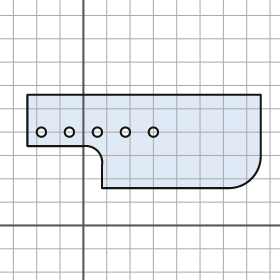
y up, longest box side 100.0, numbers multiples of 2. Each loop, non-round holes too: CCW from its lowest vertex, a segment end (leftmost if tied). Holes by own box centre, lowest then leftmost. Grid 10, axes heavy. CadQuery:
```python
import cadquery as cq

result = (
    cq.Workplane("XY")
    .moveTo(8.0, 16.0)
    .lineTo(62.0, 16.0)
    .threePointArc((72.0, 20.0), (76.0, 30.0))
    .lineTo(76.0, 56.0)
    .lineTo(-24.0, 56.0)
    .lineTo(-24.0, 34.0)
    .lineTo(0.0, 34.0)
    .threePointArc((6.0, 32.0), (8.0, 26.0))
    .close()
    .moveTo(-18.0, 40.0)
    .circle(2.0)
    .moveTo(-6.0, 40.0)
    .circle(2.0)
    .moveTo(6.0, 40.0)
    .circle(2.0)
    .moveTo(18.0, 40.0)
    .circle(2.0)
    .moveTo(30.0, 40.0)
    .circle(2.0)
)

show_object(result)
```